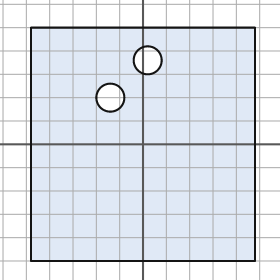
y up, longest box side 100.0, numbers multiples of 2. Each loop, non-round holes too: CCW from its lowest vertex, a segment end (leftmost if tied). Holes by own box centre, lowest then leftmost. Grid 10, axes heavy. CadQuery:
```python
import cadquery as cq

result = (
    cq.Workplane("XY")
    .moveTo(-48.0, -50.0)
    .lineTo(48.0, -50.0)
    .lineTo(48.0, 50.0)
    .lineTo(-48.0, 50.0)
    .close()
    .moveTo(-14.0, 20.0)
    .circle(6.0)
    .moveTo(2.0, 36.0)
    .circle(6.0)
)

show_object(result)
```